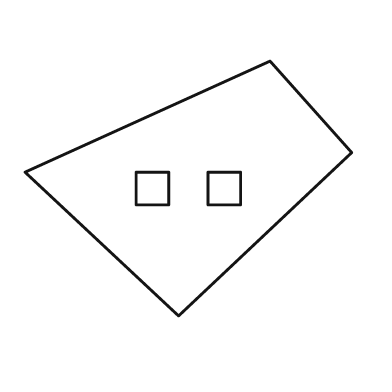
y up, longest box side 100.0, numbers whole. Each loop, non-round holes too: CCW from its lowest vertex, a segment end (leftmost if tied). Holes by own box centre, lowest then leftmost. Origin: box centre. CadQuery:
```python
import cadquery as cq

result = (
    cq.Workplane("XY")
    .moveTo(-3.0, -39.0)
    .lineTo(50.0, 11.0)
    .lineTo(25.0, 39.0)
    .lineTo(-50.0, 5.0)
    .close()
    .moveTo(-16.0, -5.0)
    .lineTo(-6.0, -5.0)
    .lineTo(-6.0, 5.0)
    .lineTo(-16.0, 5.0)
    .close()
    .moveTo(6.0, -5.0)
    .lineTo(16.0, -5.0)
    .lineTo(16.0, 5.0)
    .lineTo(6.0, 5.0)
    .close()
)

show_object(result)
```